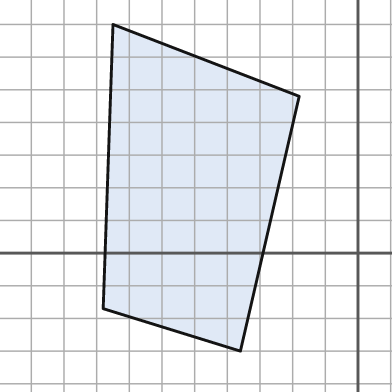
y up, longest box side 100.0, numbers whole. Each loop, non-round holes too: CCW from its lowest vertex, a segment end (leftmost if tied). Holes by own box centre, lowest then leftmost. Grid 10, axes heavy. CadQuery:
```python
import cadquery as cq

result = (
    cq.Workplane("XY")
    .moveTo(-36.0, -30.0)
    .lineTo(-18.0, 48.0)
    .lineTo(-75.0, 70.0)
    .lineTo(-78.0, -17.0)
    .close()
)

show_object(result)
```